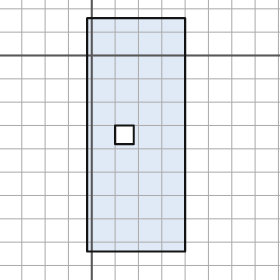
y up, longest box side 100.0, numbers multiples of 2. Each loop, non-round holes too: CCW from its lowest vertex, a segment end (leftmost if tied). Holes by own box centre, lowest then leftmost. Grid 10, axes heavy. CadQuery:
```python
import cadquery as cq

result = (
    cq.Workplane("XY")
    .moveTo(-2.0, -84.0)
    .lineTo(40.0, -84.0)
    .lineTo(40.0, 16.0)
    .lineTo(-2.0, 16.0)
    .close()
    .moveTo(10.0, -38.0)
    .lineTo(18.0, -38.0)
    .lineTo(18.0, -30.0)
    .lineTo(10.0, -30.0)
    .close()
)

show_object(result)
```